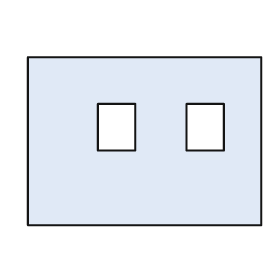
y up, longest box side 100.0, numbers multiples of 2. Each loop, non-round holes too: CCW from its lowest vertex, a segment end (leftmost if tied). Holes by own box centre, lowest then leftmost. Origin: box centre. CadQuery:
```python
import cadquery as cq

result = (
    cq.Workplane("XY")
    .moveTo(-50.0, -36.0)
    .lineTo(50.0, -36.0)
    .lineTo(50.0, 36.0)
    .lineTo(-50.0, 36.0)
    .close()
    .moveTo(-20.0, -4.0)
    .lineTo(-4.0, -4.0)
    .lineTo(-4.0, 16.0)
    .lineTo(-20.0, 16.0)
    .close()
    .moveTo(18.0, -4.0)
    .lineTo(34.0, -4.0)
    .lineTo(34.0, 16.0)
    .lineTo(18.0, 16.0)
    .close()
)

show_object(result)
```